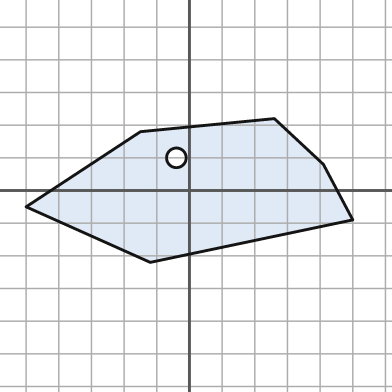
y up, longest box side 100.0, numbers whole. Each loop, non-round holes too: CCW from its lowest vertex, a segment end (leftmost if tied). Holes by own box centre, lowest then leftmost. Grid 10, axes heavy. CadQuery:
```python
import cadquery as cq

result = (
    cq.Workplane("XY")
    .moveTo(-12.0, -22.0)
    .lineTo(50.0, -9.0)
    .lineTo(41.0, 8.0)
    .lineTo(26.0, 22.0)
    .lineTo(-15.0, 18.0)
    .lineTo(-50.0, -5.0)
    .close()
    .moveTo(-4.0, 10.0)
    .circle(3.0)
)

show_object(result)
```